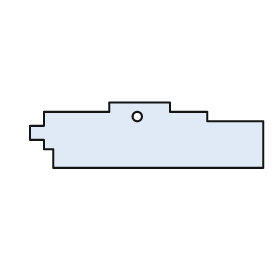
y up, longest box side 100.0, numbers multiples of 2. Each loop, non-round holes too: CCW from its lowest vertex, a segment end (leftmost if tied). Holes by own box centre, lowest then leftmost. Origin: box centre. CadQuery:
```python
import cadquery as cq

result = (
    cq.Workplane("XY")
    .moveTo(-40.0, -14.0)
    .lineTo(50.0, -14.0)
    .lineTo(50.0, 6.0)
    .lineTo(26.0, 6.0)
    .lineTo(26.0, 10.0)
    .lineTo(10.0, 10.0)
    .lineTo(10.0, 14.0)
    .lineTo(-16.0, 14.0)
    .lineTo(-16.0, 10.0)
    .lineTo(-44.0, 10.0)
    .lineTo(-44.0, 4.0)
    .lineTo(-50.0, 4.0)
    .lineTo(-50.0, -2.0)
    .lineTo(-44.0, -2.0)
    .lineTo(-44.0, -6.0)
    .lineTo(-40.0, -6.0)
    .close()
    .moveTo(-4.0, 8.0)
    .circle(2.0)
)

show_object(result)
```